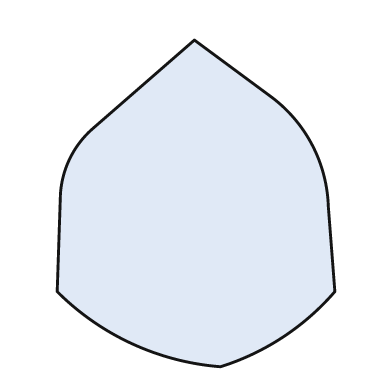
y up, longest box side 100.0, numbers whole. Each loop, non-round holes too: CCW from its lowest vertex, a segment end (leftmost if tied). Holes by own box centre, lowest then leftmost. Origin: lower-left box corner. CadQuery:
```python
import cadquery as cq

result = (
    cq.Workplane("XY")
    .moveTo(50.0, 0.0)
    .threePointArc((69.0, 9.0), (85.0, 23.0))
    .lineTo(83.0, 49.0)
    .threePointArc((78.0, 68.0), (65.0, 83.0))
    .lineTo(42.0, 100.0)
    .lineTo(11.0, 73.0)
    .threePointArc((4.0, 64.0), (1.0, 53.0))
    .lineTo(0.0, 23.0)
    .threePointArc((23.0, 7.0), (50.0, 0.0))
    .close()
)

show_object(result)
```